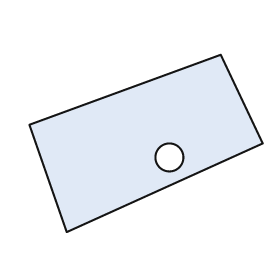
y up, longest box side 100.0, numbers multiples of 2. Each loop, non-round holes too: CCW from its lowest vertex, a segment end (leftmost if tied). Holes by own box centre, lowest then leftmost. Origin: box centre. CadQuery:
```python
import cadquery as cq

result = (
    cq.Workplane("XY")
    .moveTo(-34.0, -38.0)
    .lineTo(50.0, 0.0)
    .lineTo(32.0, 38.0)
    .lineTo(-50.0, 8.0)
    .close()
    .moveTo(10.0, -6.0)
    .circle(6.0)
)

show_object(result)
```